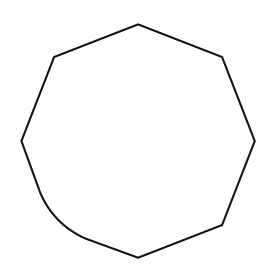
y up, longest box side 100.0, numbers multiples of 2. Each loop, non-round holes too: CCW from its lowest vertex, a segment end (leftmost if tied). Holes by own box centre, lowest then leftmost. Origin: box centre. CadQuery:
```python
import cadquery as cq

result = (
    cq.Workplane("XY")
    .moveTo(0.0, -50.0)
    .lineTo(36.0, -36.0)
    .lineTo(50.0, 0.0)
    .lineTo(36.0, 36.0)
    .lineTo(0.0, 50.0)
    .lineTo(-36.0, 36.0)
    .lineTo(-50.0, 0.0)
    .lineTo(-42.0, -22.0)
    .threePointArc((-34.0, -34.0), (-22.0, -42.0))
    .close()
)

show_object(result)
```